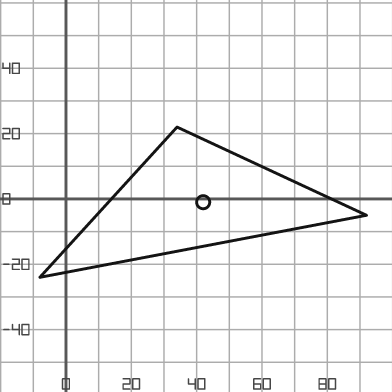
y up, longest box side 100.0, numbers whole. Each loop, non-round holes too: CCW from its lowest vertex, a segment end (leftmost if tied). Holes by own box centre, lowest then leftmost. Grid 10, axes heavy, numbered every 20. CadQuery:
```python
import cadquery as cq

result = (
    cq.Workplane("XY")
    .moveTo(-8.0, -24.0)
    .lineTo(92.0, -5.0)
    .lineTo(34.0, 22.0)
    .close()
    .moveTo(42.0, -1.0)
    .circle(2.0)
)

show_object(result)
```